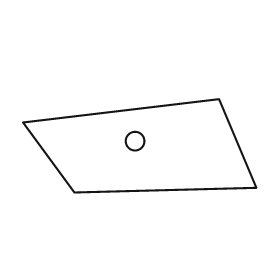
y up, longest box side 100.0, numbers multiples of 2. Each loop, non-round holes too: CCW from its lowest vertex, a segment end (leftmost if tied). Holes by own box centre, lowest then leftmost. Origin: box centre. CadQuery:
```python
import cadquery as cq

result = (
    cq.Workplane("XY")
    .moveTo(-28.0, -20.0)
    .lineTo(50.0, -18.0)
    .lineTo(34.0, 20.0)
    .lineTo(-50.0, 10.0)
    .close()
    .moveTo(-2.0, 2.0)
    .circle(4.0)
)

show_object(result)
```